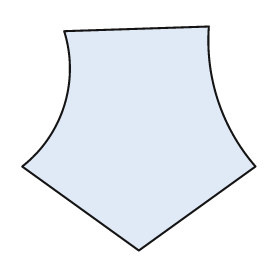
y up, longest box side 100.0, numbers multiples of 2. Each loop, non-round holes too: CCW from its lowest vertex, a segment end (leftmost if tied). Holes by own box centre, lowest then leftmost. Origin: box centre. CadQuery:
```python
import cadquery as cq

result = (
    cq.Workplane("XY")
    .moveTo(0.0, -48.0)
    .lineTo(50.0, -12.0)
    .threePointArc((34.0, 16.0), (30.0, 48.0))
    .lineTo(-32.0, 46.0)
    .threePointArc((-32.0, 14.0), (-50.0, -12.0))
    .close()
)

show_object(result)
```